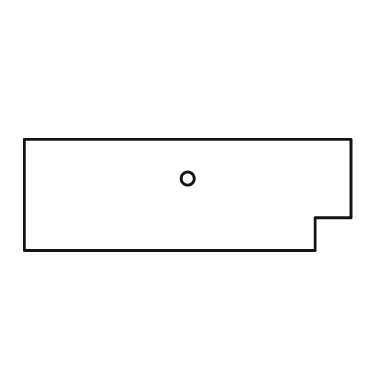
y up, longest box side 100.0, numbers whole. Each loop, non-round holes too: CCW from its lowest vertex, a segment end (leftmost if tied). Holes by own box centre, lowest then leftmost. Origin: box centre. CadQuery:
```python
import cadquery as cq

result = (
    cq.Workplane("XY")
    .moveTo(-50.0, -17.0)
    .lineTo(39.0, -17.0)
    .lineTo(39.0, -7.0)
    .lineTo(50.0, -7.0)
    .lineTo(50.0, 17.0)
    .lineTo(-50.0, 17.0)
    .close()
    .moveTo(0.0, 5.0)
    .circle(2.0)
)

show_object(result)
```